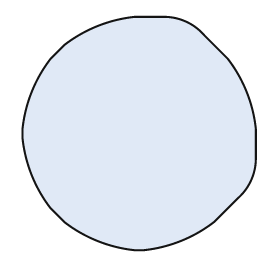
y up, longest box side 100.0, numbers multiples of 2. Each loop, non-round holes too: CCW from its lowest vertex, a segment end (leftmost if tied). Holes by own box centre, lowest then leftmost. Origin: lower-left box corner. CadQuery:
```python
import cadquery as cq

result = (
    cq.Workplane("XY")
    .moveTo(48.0, 0.0)
    .lineTo(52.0, 0.0)
    .threePointArc((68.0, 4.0), (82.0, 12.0))
    .lineTo(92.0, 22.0)
    .threePointArc((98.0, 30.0), (100.0, 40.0))
    .lineTo(100.0, 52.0)
    .threePointArc((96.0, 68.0), (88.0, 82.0))
    .lineTo(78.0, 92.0)
    .threePointArc((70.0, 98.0), (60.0, 100.0))
    .lineTo(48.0, 100.0)
    .threePointArc((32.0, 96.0), (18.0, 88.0))
    .lineTo(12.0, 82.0)
    .threePointArc((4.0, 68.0), (0.0, 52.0))
    .lineTo(0.0, 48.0)
    .threePointArc((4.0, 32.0), (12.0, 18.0))
    .lineTo(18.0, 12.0)
    .threePointArc((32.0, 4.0), (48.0, 0.0))
    .close()
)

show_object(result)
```